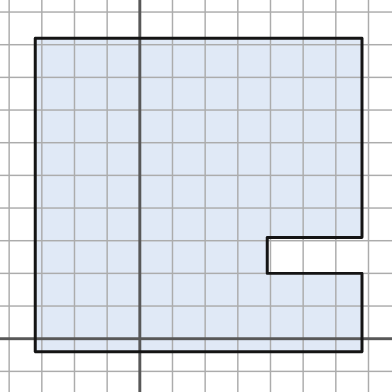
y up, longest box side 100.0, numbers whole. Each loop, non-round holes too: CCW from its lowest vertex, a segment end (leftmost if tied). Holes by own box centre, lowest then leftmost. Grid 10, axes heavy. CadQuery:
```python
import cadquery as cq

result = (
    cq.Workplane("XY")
    .moveTo(-32.0, -4.0)
    .lineTo(68.0, -4.0)
    .lineTo(68.0, 20.0)
    .lineTo(39.0, 20.0)
    .lineTo(39.0, 31.0)
    .lineTo(68.0, 31.0)
    .lineTo(68.0, 92.0)
    .lineTo(-32.0, 92.0)
    .close()
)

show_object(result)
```